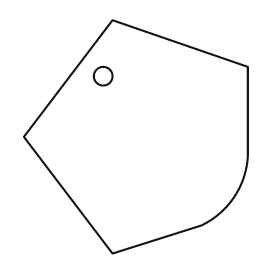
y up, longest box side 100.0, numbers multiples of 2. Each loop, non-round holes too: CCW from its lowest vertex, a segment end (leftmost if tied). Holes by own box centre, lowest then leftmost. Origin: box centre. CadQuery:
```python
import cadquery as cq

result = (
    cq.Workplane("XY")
    .moveTo(-10.0, -50.0)
    .lineTo(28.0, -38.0)
    .threePointArc((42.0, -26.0), (48.0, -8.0))
    .lineTo(48.0, 30.0)
    .lineTo(-10.0, 50.0)
    .lineTo(-48.0, 0.0)
    .close()
    .moveTo(-14.0, 26.0)
    .circle(4.0)
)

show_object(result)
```